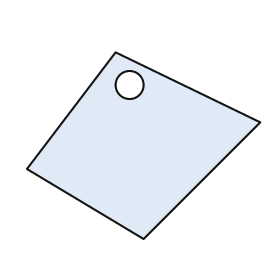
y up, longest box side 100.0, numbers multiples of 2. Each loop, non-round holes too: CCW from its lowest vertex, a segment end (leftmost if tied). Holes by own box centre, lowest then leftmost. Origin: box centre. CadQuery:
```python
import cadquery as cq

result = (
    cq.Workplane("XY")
    .moveTo(0.0, -40.0)
    .lineTo(50.0, 10.0)
    .lineTo(-12.0, 40.0)
    .lineTo(-50.0, -10.0)
    .close()
    .moveTo(-6.0, 26.0)
    .circle(6.0)
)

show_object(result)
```